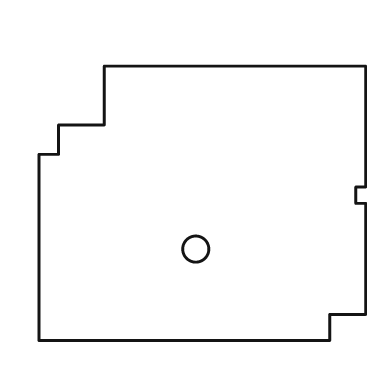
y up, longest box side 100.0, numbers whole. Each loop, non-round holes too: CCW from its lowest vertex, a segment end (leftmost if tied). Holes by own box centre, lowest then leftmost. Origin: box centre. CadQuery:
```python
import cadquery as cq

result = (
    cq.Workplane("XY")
    .moveTo(-50.0, -42.0)
    .lineTo(39.0, -42.0)
    .lineTo(39.0, -34.0)
    .lineTo(50.0, -34.0)
    .lineTo(50.0, 0.0)
    .lineTo(47.0, 0.0)
    .lineTo(47.0, 5.0)
    .lineTo(50.0, 5.0)
    .lineTo(50.0, 42.0)
    .lineTo(-30.0, 42.0)
    .lineTo(-30.0, 24.0)
    .lineTo(-44.0, 24.0)
    .lineTo(-44.0, 15.0)
    .lineTo(-50.0, 15.0)
    .close()
    .moveTo(-2.0, -14.0)
    .circle(4.0)
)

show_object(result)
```